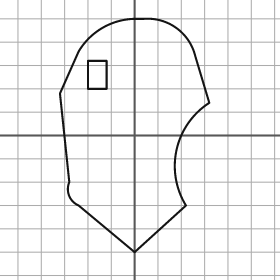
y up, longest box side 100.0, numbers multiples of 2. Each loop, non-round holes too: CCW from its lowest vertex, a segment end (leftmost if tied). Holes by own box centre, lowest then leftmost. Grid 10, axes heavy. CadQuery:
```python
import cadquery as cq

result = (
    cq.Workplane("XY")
    .moveTo(0.0, -50.0)
    .lineTo(22.0, -30.0)
    .threePointArc((18.0, -6.0), (32.0, 14.0))
    .lineTo(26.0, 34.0)
    .threePointArc((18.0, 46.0), (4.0, 50.0))
    .lineTo(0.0, 50.0)
    .threePointArc((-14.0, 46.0), (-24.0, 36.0))
    .lineTo(-32.0, 18.0)
    .lineTo(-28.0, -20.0)
    .threePointArc((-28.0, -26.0), (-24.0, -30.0))
    .close()
    .moveTo(-20.0, 20.0)
    .lineTo(-12.0, 20.0)
    .lineTo(-12.0, 32.0)
    .lineTo(-20.0, 32.0)
    .close()
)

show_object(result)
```